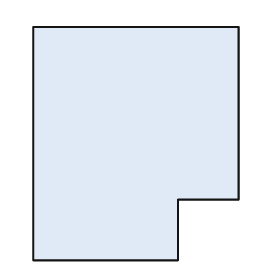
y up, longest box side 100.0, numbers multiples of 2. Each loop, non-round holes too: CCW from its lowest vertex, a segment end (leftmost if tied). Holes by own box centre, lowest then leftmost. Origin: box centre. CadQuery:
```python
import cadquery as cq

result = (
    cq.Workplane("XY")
    .moveTo(-44.0, -50.0)
    .lineTo(18.0, -50.0)
    .lineTo(18.0, -24.0)
    .lineTo(44.0, -24.0)
    .lineTo(44.0, 50.0)
    .lineTo(-44.0, 50.0)
    .close()
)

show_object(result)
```